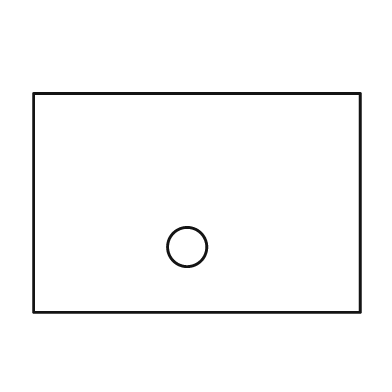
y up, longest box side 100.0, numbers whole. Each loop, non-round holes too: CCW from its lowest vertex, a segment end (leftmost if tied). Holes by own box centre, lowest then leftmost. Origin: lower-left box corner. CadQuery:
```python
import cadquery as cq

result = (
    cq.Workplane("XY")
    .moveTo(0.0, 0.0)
    .lineTo(100.0, 0.0)
    .lineTo(100.0, 67.0)
    .lineTo(0.0, 67.0)
    .close()
    .moveTo(47.0, 20.0)
    .circle(6.0)
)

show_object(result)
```